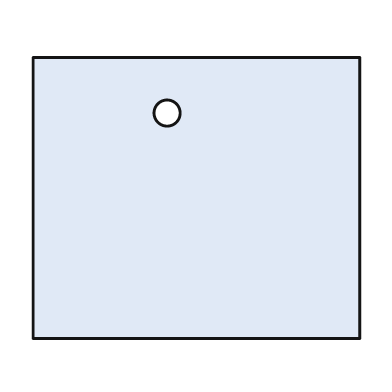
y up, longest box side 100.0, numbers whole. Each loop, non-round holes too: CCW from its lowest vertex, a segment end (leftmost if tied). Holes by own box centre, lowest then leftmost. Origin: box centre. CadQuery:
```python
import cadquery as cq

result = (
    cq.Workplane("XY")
    .moveTo(-50.0, -43.0)
    .lineTo(50.0, -43.0)
    .lineTo(50.0, 43.0)
    .lineTo(-50.0, 43.0)
    .close()
    .moveTo(-9.0, 26.0)
    .circle(4.0)
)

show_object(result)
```